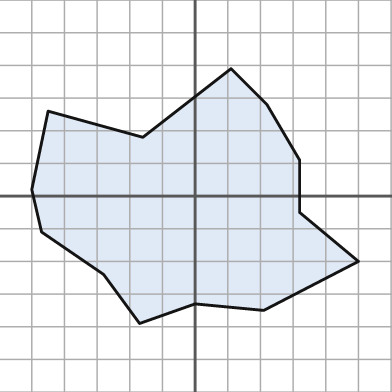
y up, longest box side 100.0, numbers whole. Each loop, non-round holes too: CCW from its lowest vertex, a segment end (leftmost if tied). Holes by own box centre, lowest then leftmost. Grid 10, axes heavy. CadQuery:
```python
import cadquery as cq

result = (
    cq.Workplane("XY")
    .moveTo(-17.0, -39.0)
    .lineTo(0.0, -33.0)
    .lineTo(21.0, -35.0)
    .lineTo(50.0, -20.0)
    .lineTo(32.0, -5.0)
    .lineTo(32.0, 11.0)
    .lineTo(22.0, 28.0)
    .lineTo(11.0, 39.0)
    .lineTo(-16.0, 18.0)
    .lineTo(-45.0, 26.0)
    .lineTo(-50.0, 2.0)
    .lineTo(-47.0, -11.0)
    .lineTo(-28.0, -24.0)
    .close()
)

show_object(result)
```